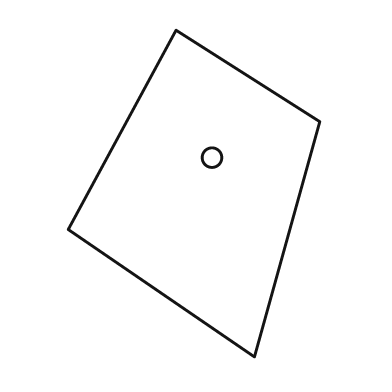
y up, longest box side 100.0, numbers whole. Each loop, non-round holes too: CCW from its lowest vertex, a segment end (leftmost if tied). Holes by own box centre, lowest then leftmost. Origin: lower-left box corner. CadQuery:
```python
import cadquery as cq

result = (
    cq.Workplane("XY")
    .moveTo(57.0, 0.0)
    .lineTo(77.0, 72.0)
    .lineTo(33.0, 100.0)
    .lineTo(0.0, 39.0)
    .close()
    .moveTo(44.0, 61.0)
    .circle(3.0)
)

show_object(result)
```